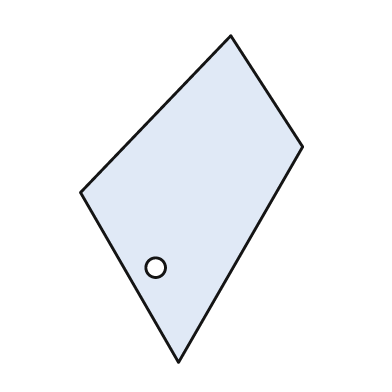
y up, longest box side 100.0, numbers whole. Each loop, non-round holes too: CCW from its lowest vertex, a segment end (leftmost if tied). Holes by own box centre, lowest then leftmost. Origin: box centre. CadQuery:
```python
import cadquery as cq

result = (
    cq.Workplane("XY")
    .moveTo(-4.0, -50.0)
    .lineTo(34.0, 16.0)
    .lineTo(12.0, 50.0)
    .lineTo(-34.0, 2.0)
    .close()
    .moveTo(-11.0, -21.0)
    .circle(3.0)
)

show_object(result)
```